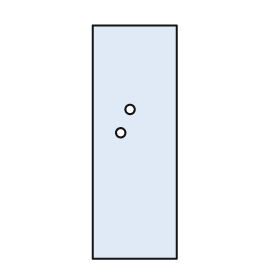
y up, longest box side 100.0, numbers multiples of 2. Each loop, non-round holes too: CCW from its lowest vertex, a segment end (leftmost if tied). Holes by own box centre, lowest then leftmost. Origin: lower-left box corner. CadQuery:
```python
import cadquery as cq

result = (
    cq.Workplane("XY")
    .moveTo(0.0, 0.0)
    .lineTo(36.0, 0.0)
    .lineTo(36.0, 100.0)
    .lineTo(0.0, 100.0)
    .close()
    .moveTo(12.0, 54.0)
    .circle(2.0)
    .moveTo(16.0, 64.0)
    .circle(2.0)
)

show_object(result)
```